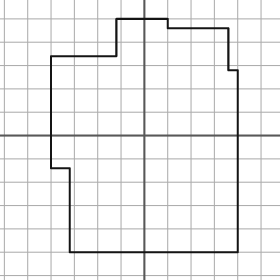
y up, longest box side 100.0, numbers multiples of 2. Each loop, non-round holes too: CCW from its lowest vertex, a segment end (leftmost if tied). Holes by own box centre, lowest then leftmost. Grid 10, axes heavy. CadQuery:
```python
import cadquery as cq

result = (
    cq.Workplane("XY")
    .moveTo(-32.0, -50.0)
    .lineTo(40.0, -50.0)
    .lineTo(40.0, 28.0)
    .lineTo(36.0, 28.0)
    .lineTo(36.0, 46.0)
    .lineTo(10.0, 46.0)
    .lineTo(10.0, 50.0)
    .lineTo(-12.0, 50.0)
    .lineTo(-12.0, 34.0)
    .lineTo(-40.0, 34.0)
    .lineTo(-40.0, -14.0)
    .lineTo(-32.0, -14.0)
    .close()
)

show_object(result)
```